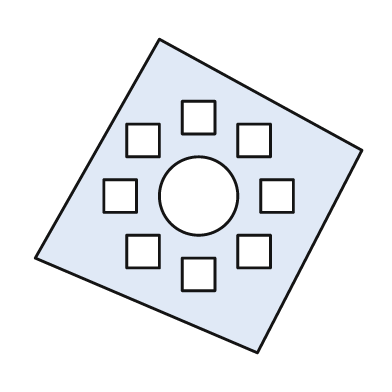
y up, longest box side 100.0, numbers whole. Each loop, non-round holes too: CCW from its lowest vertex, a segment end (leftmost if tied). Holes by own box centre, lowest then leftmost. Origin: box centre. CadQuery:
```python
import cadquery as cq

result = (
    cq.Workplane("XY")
    .moveTo(18.0, -48.0)
    .lineTo(50.0, 14.0)
    .lineTo(-12.0, 48.0)
    .lineTo(-50.0, -19.0)
    .close()
    .moveTo(-5.0, -29.0)
    .lineTo(5.0, -29.0)
    .lineTo(5.0, -19.0)
    .lineTo(-5.0, -19.0)
    .close()
    .moveTo(-22.0, -22.0)
    .lineTo(-12.0, -22.0)
    .lineTo(-12.0, -12.0)
    .lineTo(-22.0, -12.0)
    .close()
    .moveTo(12.0, -22.0)
    .lineTo(22.0, -22.0)
    .lineTo(22.0, -12.0)
    .lineTo(12.0, -12.0)
    .close()
    .moveTo(-29.0, -5.0)
    .lineTo(-19.0, -5.0)
    .lineTo(-19.0, 5.0)
    .lineTo(-29.0, 5.0)
    .close()
    .moveTo(0.0, 0.0)
    .circle(12.0)
    .moveTo(19.0, -5.0)
    .lineTo(29.0, -5.0)
    .lineTo(29.0, 5.0)
    .lineTo(19.0, 5.0)
    .close()
    .moveTo(-22.0, 12.0)
    .lineTo(-12.0, 12.0)
    .lineTo(-12.0, 22.0)
    .lineTo(-22.0, 22.0)
    .close()
    .moveTo(12.0, 12.0)
    .lineTo(22.0, 12.0)
    .lineTo(22.0, 22.0)
    .lineTo(12.0, 22.0)
    .close()
    .moveTo(-5.0, 19.0)
    .lineTo(5.0, 19.0)
    .lineTo(5.0, 29.0)
    .lineTo(-5.0, 29.0)
    .close()
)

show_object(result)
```